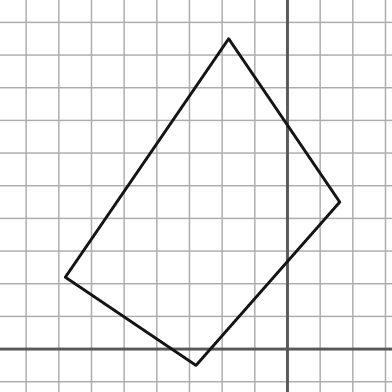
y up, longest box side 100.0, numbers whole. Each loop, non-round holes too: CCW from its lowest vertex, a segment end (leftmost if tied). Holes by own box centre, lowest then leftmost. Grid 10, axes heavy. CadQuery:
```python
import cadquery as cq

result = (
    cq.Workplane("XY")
    .moveTo(-28.0, -5.0)
    .lineTo(16.0, 45.0)
    .lineTo(-18.0, 95.0)
    .lineTo(-68.0, 22.0)
    .close()
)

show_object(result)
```